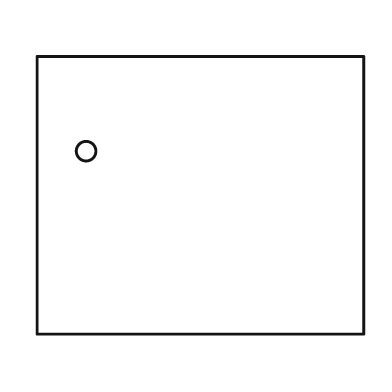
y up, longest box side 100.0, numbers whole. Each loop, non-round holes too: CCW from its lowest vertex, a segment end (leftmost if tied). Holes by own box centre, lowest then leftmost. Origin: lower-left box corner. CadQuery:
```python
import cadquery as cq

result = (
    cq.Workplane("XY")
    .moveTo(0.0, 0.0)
    .lineTo(100.0, 0.0)
    .lineTo(100.0, 85.0)
    .lineTo(0.0, 85.0)
    .close()
    .moveTo(15.0, 56.0)
    .circle(3.0)
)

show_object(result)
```